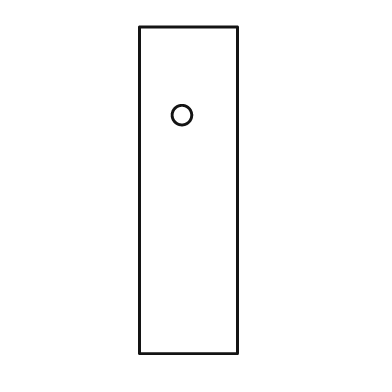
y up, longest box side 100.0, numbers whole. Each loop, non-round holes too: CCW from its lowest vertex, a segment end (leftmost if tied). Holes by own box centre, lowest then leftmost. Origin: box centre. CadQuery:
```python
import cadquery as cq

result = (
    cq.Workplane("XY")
    .moveTo(-15.0, -50.0)
    .lineTo(15.0, -50.0)
    .lineTo(15.0, 50.0)
    .lineTo(-15.0, 50.0)
    .close()
    .moveTo(-2.0, 23.0)
    .circle(3.0)
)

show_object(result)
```